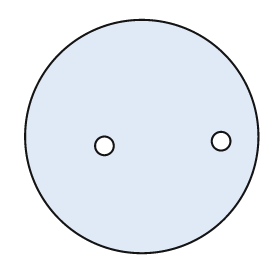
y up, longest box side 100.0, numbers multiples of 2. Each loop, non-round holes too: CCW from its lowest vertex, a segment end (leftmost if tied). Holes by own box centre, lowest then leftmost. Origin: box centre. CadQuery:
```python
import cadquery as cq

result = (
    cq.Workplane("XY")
    .moveTo(0.0, 0.0)
    .circle(50.0)
    .moveTo(-16.0, -4.0)
    .circle(4.0)
    .moveTo(34.0, -2.0)
    .circle(4.0)
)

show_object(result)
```